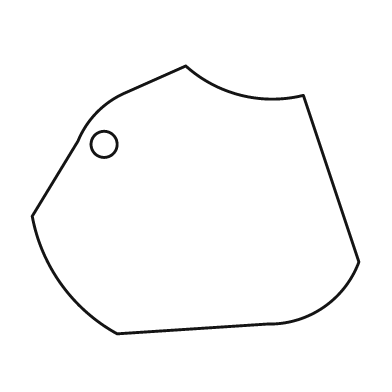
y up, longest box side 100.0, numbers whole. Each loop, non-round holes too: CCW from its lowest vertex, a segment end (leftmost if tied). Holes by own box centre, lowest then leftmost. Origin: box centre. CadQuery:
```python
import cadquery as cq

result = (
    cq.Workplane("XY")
    .moveTo(-24.0, -41.0)
    .lineTo(22.0, -38.0)
    .threePointArc((39.0, -33.0), (50.0, -19.0))
    .lineTo(33.0, 32.0)
    .threePointArc((14.0, 32.0), (-3.0, 41.0))
    .lineTo(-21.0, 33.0)
    .threePointArc((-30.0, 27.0), (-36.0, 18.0))
    .lineTo(-50.0, -5.0)
    .threePointArc((-41.0, -26.0), (-24.0, -41.0))
    .close()
    .moveTo(-28.0, 17.0)
    .circle(4.0)
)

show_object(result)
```